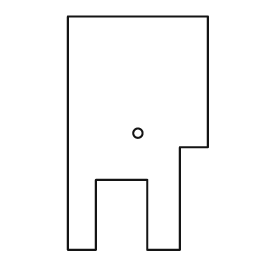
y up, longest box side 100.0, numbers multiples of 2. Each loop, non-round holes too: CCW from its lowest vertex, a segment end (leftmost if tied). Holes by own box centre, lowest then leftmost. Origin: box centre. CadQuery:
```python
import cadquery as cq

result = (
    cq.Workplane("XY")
    .moveTo(-30.0, -50.0)
    .lineTo(-18.0, -50.0)
    .lineTo(-18.0, -20.0)
    .lineTo(4.0, -20.0)
    .lineTo(4.0, -50.0)
    .lineTo(18.0, -50.0)
    .lineTo(18.0, -6.0)
    .lineTo(30.0, -6.0)
    .lineTo(30.0, 50.0)
    .lineTo(-30.0, 50.0)
    .close()
    .moveTo(0.0, 0.0)
    .circle(2.0)
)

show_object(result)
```